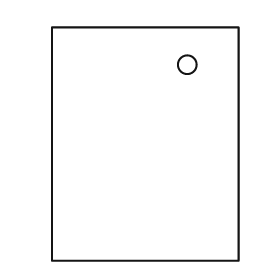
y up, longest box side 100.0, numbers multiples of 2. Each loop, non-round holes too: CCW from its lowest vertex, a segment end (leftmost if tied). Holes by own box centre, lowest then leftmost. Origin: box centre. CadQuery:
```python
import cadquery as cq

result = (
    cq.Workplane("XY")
    .moveTo(-40.0, -50.0)
    .lineTo(40.0, -50.0)
    .lineTo(40.0, 50.0)
    .lineTo(-40.0, 50.0)
    .close()
    .moveTo(18.0, 34.0)
    .circle(4.0)
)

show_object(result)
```